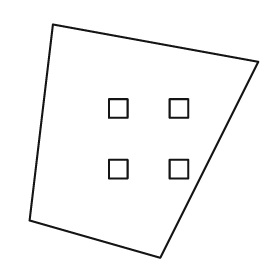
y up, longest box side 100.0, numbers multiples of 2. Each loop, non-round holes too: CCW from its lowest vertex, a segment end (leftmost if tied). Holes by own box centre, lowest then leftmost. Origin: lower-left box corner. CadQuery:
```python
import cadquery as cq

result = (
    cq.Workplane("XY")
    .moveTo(56.0, 0.0)
    .lineTo(98.0, 84.0)
    .lineTo(10.0, 100.0)
    .lineTo(0.0, 16.0)
    .close()
    .moveTo(34.0, 34.0)
    .lineTo(42.0, 34.0)
    .lineTo(42.0, 42.0)
    .lineTo(34.0, 42.0)
    .close()
    .moveTo(60.0, 34.0)
    .lineTo(68.0, 34.0)
    .lineTo(68.0, 42.0)
    .lineTo(60.0, 42.0)
    .close()
    .moveTo(34.0, 60.0)
    .lineTo(42.0, 60.0)
    .lineTo(42.0, 68.0)
    .lineTo(34.0, 68.0)
    .close()
    .moveTo(60.0, 60.0)
    .lineTo(68.0, 60.0)
    .lineTo(68.0, 68.0)
    .lineTo(60.0, 68.0)
    .close()
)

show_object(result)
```